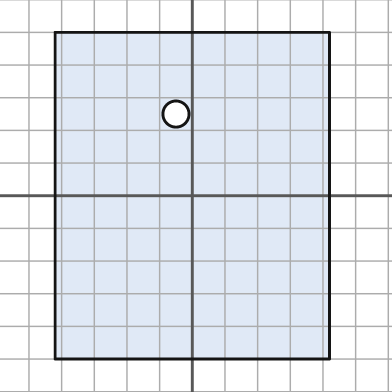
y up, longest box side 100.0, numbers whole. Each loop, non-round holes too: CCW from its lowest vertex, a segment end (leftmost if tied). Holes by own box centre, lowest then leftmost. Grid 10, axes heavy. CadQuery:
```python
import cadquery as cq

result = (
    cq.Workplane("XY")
    .moveTo(-42.0, -50.0)
    .lineTo(42.0, -50.0)
    .lineTo(42.0, 50.0)
    .lineTo(-42.0, 50.0)
    .close()
    .moveTo(-5.0, 25.0)
    .circle(4.0)
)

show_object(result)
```